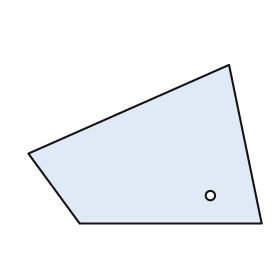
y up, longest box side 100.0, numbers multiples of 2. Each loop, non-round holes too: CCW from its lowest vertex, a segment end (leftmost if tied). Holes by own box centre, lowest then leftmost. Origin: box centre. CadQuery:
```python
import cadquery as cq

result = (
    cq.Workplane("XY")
    .moveTo(-28.0, -34.0)
    .lineTo(50.0, -34.0)
    .lineTo(36.0, 34.0)
    .lineTo(-50.0, -4.0)
    .close()
    .moveTo(28.0, -22.0)
    .circle(2.0)
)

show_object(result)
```